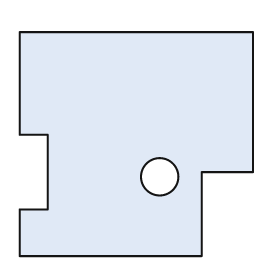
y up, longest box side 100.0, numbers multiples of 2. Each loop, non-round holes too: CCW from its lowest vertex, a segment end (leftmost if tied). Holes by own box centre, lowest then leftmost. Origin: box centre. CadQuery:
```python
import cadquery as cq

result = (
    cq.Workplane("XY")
    .moveTo(-50.0, -48.0)
    .lineTo(28.0, -48.0)
    .lineTo(28.0, -12.0)
    .lineTo(50.0, -12.0)
    .lineTo(50.0, 48.0)
    .lineTo(-50.0, 48.0)
    .lineTo(-50.0, 4.0)
    .lineTo(-38.0, 4.0)
    .lineTo(-38.0, -28.0)
    .lineTo(-50.0, -28.0)
    .close()
    .moveTo(10.0, -14.0)
    .circle(8.0)
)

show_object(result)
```